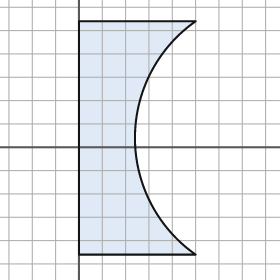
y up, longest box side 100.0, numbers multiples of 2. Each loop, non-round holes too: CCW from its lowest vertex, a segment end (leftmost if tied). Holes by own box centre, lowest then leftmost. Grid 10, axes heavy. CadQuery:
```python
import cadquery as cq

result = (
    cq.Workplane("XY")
    .moveTo(0.0, -46.0)
    .lineTo(50.0, -46.0)
    .threePointArc((24.0, 4.0), (50.0, 54.0))
    .lineTo(0.0, 54.0)
    .close()
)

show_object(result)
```